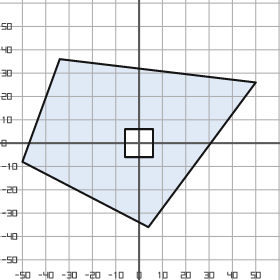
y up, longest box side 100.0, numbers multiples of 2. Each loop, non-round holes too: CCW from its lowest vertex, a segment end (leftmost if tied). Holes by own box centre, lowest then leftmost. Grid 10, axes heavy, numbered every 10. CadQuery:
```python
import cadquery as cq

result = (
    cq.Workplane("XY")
    .moveTo(4.0, -36.0)
    .lineTo(50.0, 26.0)
    .lineTo(-34.0, 36.0)
    .lineTo(-50.0, -8.0)
    .close()
    .moveTo(-6.0, -6.0)
    .lineTo(6.0, -6.0)
    .lineTo(6.0, 6.0)
    .lineTo(-6.0, 6.0)
    .close()
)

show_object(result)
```